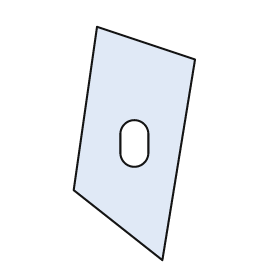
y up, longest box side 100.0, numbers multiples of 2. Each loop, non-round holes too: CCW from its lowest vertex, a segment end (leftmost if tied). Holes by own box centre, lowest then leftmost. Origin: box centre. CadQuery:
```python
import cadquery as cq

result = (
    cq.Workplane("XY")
    .moveTo(12.0, -50.0)
    .lineTo(26.0, 36.0)
    .lineTo(-16.0, 50.0)
    .lineTo(-26.0, -20.0)
    .close()
    .moveTo(-6.0, -4.0)
    .threePointArc((0.0, -10.0), (6.0, -4.0))
    .lineTo(6.0, 4.0)
    .threePointArc((0.0, 10.0), (-6.0, 4.0))
    .close()
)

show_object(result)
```